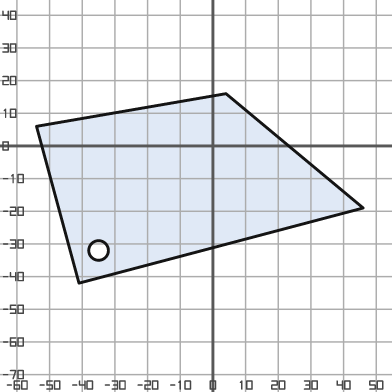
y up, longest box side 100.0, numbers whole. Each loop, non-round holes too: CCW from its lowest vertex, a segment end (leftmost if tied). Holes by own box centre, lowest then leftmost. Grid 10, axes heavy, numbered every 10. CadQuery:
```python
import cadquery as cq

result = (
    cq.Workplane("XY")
    .moveTo(-41.0, -42.0)
    .lineTo(46.0, -19.0)
    .lineTo(4.0, 16.0)
    .lineTo(-54.0, 6.0)
    .close()
    .moveTo(-35.0, -32.0)
    .circle(3.0)
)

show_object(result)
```